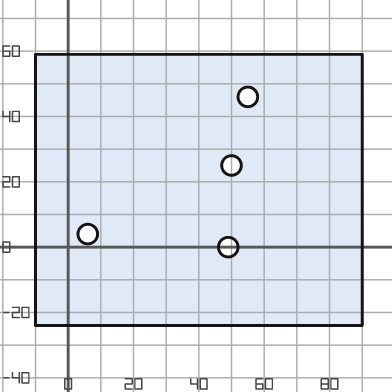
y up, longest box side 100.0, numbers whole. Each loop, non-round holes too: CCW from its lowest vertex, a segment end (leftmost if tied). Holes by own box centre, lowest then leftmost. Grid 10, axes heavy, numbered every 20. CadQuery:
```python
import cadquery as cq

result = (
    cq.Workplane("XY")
    .moveTo(-10.0, -24.0)
    .lineTo(90.0, -24.0)
    .lineTo(90.0, 59.0)
    .lineTo(-10.0, 59.0)
    .close()
    .moveTo(49.0, 0.0)
    .circle(3.0)
    .moveTo(6.0, 4.0)
    .circle(3.0)
    .moveTo(50.0, 25.0)
    .circle(3.0)
    .moveTo(55.0, 46.0)
    .circle(3.0)
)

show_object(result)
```